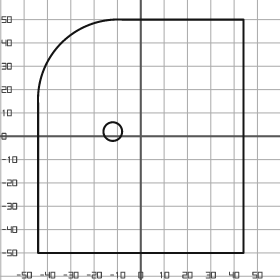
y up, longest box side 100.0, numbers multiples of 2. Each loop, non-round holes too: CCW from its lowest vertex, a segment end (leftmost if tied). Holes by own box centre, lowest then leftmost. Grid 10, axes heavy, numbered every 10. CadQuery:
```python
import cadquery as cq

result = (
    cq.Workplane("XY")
    .moveTo(-44.0, -50.0)
    .lineTo(44.0, -50.0)
    .lineTo(44.0, 50.0)
    .lineTo(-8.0, 50.0)
    .threePointArc((-34.0, 40.0), (-44.0, 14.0))
    .close()
    .moveTo(-12.0, 2.0)
    .circle(4.0)
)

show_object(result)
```